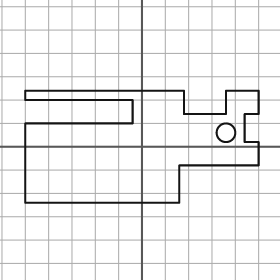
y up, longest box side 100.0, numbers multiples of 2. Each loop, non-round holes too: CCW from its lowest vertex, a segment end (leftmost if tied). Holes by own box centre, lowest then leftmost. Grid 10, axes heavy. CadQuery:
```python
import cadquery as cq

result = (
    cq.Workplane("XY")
    .moveTo(-50.0, -24.0)
    .lineTo(16.0, -24.0)
    .lineTo(16.0, -8.0)
    .lineTo(50.0, -8.0)
    .lineTo(50.0, 2.0)
    .lineTo(44.0, 2.0)
    .lineTo(44.0, 14.0)
    .lineTo(50.0, 14.0)
    .lineTo(50.0, 24.0)
    .lineTo(36.0, 24.0)
    .lineTo(36.0, 14.0)
    .lineTo(18.0, 14.0)
    .lineTo(18.0, 24.0)
    .lineTo(-50.0, 24.0)
    .lineTo(-50.0, 20.0)
    .lineTo(-4.0, 20.0)
    .lineTo(-4.0, 10.0)
    .lineTo(-50.0, 10.0)
    .close()
    .moveTo(36.0, 6.0)
    .circle(4.0)
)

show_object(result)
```